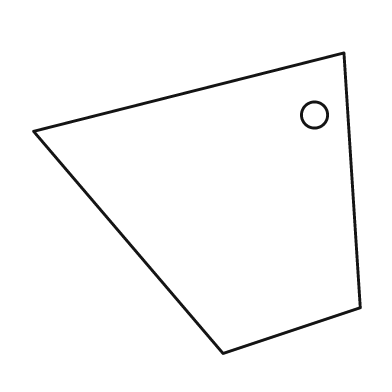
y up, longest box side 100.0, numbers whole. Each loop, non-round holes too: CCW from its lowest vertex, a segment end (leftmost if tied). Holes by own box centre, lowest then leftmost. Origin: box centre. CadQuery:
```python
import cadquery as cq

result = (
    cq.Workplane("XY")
    .moveTo(8.0, -46.0)
    .lineTo(50.0, -32.0)
    .lineTo(45.0, 46.0)
    .lineTo(-50.0, 22.0)
    .close()
    .moveTo(36.0, 27.0)
    .circle(4.0)
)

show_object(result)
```